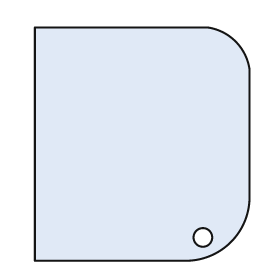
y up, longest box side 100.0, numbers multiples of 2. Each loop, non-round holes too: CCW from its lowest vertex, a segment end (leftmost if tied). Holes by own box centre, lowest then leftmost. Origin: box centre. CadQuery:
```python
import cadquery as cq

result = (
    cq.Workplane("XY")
    .moveTo(-46.0, -50.0)
    .lineTo(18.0, -50.0)
    .threePointArc((38.0, -42.0), (46.0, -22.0))
    .lineTo(46.0, 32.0)
    .threePointArc((40.0, 44.0), (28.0, 50.0))
    .lineTo(-46.0, 50.0)
    .close()
    .moveTo(26.0, -40.0)
    .circle(4.0)
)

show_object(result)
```